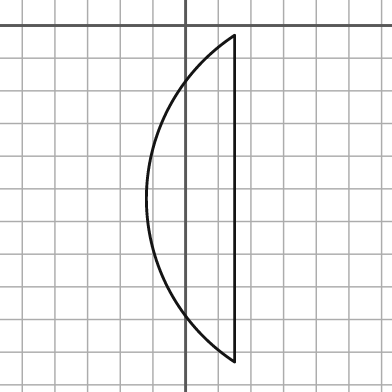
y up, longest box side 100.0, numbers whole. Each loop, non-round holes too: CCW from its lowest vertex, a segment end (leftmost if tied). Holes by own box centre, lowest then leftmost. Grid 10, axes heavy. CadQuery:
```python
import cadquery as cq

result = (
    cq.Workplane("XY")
    .moveTo(15.0, -103.0)
    .lineTo(15.0, -3.0)
    .threePointArc((-12.0, -53.0), (15.0, -103.0))
    .close()
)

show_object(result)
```